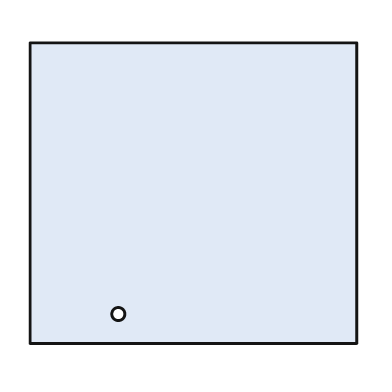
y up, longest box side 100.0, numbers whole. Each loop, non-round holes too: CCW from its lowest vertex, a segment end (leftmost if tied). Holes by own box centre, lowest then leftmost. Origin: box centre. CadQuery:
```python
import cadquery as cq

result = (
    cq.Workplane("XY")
    .moveTo(-50.0, -46.0)
    .lineTo(50.0, -46.0)
    .lineTo(50.0, 46.0)
    .lineTo(-50.0, 46.0)
    .close()
    .moveTo(-23.0, -37.0)
    .circle(2.0)
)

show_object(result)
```